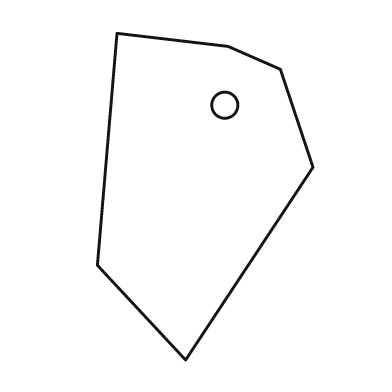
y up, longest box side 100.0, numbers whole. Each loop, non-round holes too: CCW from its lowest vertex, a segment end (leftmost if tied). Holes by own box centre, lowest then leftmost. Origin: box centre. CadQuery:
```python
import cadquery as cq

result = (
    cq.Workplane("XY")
    .moveTo(-6.0, -50.0)
    .lineTo(33.0, 9.0)
    .lineTo(23.0, 39.0)
    .lineTo(7.0, 46.0)
    .lineTo(-27.0, 50.0)
    .lineTo(-33.0, -21.0)
    .close()
    .moveTo(6.0, 28.0)
    .circle(4.0)
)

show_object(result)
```